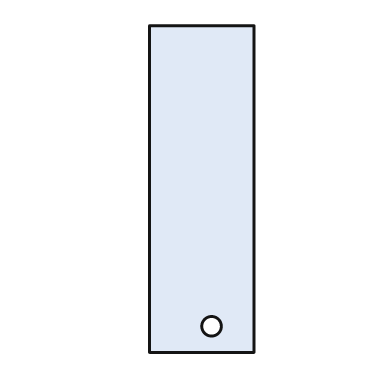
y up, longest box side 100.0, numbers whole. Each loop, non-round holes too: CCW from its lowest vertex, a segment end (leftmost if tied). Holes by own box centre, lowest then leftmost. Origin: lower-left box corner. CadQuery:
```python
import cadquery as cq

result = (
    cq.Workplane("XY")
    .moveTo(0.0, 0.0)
    .lineTo(32.0, 0.0)
    .lineTo(32.0, 100.0)
    .lineTo(0.0, 100.0)
    .close()
    .moveTo(19.0, 8.0)
    .circle(3.0)
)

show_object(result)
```